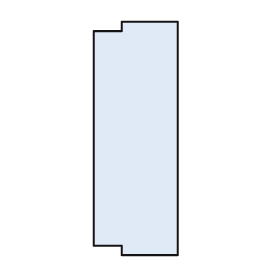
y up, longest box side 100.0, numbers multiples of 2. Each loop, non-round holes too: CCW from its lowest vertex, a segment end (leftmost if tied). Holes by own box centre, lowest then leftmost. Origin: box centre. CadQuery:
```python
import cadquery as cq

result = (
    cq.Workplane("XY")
    .moveTo(-6.0, -50.0)
    .lineTo(18.0, -50.0)
    .lineTo(18.0, 50.0)
    .lineTo(-6.0, 50.0)
    .lineTo(-6.0, 46.0)
    .lineTo(-18.0, 46.0)
    .lineTo(-18.0, -46.0)
    .lineTo(-6.0, -46.0)
    .close()
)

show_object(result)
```